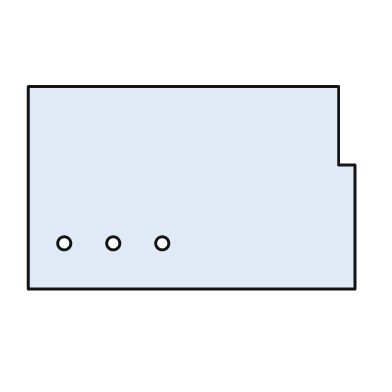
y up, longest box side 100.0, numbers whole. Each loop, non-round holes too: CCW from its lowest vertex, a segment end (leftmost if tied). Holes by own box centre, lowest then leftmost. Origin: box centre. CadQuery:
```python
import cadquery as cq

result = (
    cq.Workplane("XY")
    .moveTo(-50.0, -31.0)
    .lineTo(50.0, -31.0)
    .lineTo(50.0, 7.0)
    .lineTo(45.0, 7.0)
    .lineTo(45.0, 31.0)
    .lineTo(-50.0, 31.0)
    .close()
    .moveTo(-39.0, -17.0)
    .circle(2.0)
    .moveTo(-24.0, -17.0)
    .circle(2.0)
    .moveTo(-9.0, -17.0)
    .circle(2.0)
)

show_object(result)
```